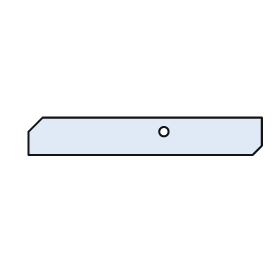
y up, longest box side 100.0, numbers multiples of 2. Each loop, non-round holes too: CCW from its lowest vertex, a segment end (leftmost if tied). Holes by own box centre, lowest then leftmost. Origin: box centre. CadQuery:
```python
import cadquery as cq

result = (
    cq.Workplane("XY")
    .moveTo(-50.0, -8.0)
    .lineTo(46.0, -8.0)
    .lineTo(50.0, -4.0)
    .lineTo(50.0, 8.0)
    .lineTo(-44.0, 8.0)
    .lineTo(-50.0, 2.0)
    .close()
    .moveTo(8.0, 2.0)
    .circle(2.0)
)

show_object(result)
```